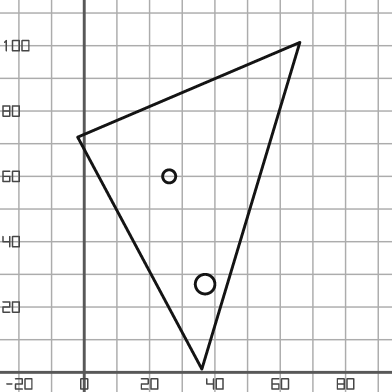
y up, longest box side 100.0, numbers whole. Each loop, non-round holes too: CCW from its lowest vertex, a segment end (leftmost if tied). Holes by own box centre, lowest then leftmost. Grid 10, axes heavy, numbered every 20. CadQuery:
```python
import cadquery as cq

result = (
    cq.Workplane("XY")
    .moveTo(36.0, 1.0)
    .lineTo(66.0, 101.0)
    .lineTo(-2.0, 72.0)
    .close()
    .moveTo(37.0, 27.0)
    .circle(3.0)
    .moveTo(26.0, 60.0)
    .circle(2.0)
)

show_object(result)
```